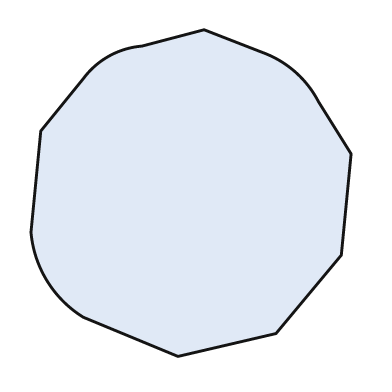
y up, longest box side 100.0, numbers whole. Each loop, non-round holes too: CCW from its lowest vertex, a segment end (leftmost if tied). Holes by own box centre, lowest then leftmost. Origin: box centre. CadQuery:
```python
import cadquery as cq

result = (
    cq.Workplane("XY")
    .moveTo(-4.0, -50.0)
    .lineTo(26.0, -43.0)
    .lineTo(46.0, -19.0)
    .lineTo(49.0, 12.0)
    .lineTo(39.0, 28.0)
    .threePointArc((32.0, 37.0), (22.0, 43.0))
    .lineTo(4.0, 50.0)
    .lineTo(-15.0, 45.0)
    .threePointArc((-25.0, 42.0), (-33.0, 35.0))
    .lineTo(-46.0, 19.0)
    .lineTo(-49.0, -12.0)
    .threePointArc((-44.0, -27.0), (-33.0, -38.0))
    .close()
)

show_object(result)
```